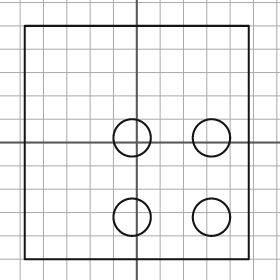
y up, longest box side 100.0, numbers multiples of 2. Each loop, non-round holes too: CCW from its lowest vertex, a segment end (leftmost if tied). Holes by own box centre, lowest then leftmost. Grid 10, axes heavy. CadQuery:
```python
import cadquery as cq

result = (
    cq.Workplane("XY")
    .moveTo(-48.0, -50.0)
    .lineTo(48.0, -50.0)
    .lineTo(48.0, 50.0)
    .lineTo(-48.0, 50.0)
    .close()
    .moveTo(-2.0, -32.0)
    .circle(8.0)
    .moveTo(32.0, -32.0)
    .circle(8.0)
    .moveTo(-2.0, 2.0)
    .circle(8.0)
    .moveTo(32.0, 2.0)
    .circle(8.0)
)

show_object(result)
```